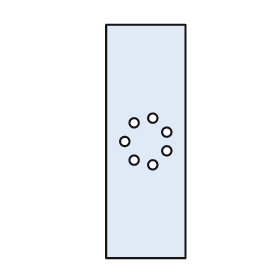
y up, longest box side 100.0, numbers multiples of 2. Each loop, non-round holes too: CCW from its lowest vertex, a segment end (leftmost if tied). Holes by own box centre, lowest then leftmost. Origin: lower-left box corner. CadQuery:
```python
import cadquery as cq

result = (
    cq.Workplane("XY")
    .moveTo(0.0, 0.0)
    .lineTo(34.0, 0.0)
    .lineTo(34.0, 100.0)
    .lineTo(0.0, 100.0)
    .close()
    .moveTo(20.0, 40.0)
    .circle(2.0)
    .moveTo(12.0, 42.0)
    .circle(2.0)
    .moveTo(26.0, 46.0)
    .circle(2.0)
    .moveTo(8.0, 50.0)
    .circle(2.0)
    .moveTo(26.0, 54.0)
    .circle(2.0)
    .moveTo(12.0, 58.0)
    .circle(2.0)
    .moveTo(20.0, 60.0)
    .circle(2.0)
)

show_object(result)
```